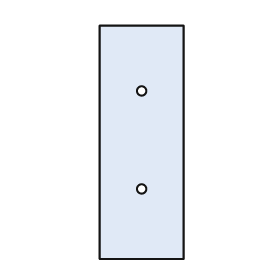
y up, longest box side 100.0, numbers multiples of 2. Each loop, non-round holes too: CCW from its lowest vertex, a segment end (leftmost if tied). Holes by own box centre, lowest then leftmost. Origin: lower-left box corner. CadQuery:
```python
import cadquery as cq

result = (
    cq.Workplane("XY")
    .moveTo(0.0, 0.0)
    .lineTo(36.0, 0.0)
    .lineTo(36.0, 100.0)
    .lineTo(0.0, 100.0)
    .close()
    .moveTo(18.0, 30.0)
    .circle(2.0)
    .moveTo(18.0, 72.0)
    .circle(2.0)
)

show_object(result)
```